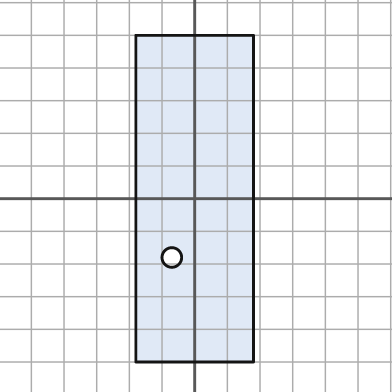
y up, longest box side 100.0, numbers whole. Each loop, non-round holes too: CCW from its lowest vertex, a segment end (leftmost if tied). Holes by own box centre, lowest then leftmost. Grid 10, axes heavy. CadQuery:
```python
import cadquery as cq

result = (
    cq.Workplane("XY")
    .moveTo(-18.0, -50.0)
    .lineTo(18.0, -50.0)
    .lineTo(18.0, 50.0)
    .lineTo(-18.0, 50.0)
    .close()
    .moveTo(-7.0, -18.0)
    .circle(3.0)
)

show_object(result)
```